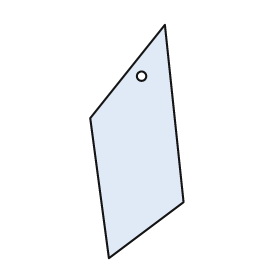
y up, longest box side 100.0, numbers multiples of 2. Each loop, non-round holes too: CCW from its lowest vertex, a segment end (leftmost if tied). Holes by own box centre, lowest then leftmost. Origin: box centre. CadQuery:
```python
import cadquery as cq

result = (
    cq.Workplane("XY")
    .moveTo(-12.0, -50.0)
    .lineTo(20.0, -26.0)
    .lineTo(12.0, 50.0)
    .lineTo(-20.0, 10.0)
    .close()
    .moveTo(2.0, 28.0)
    .circle(2.0)
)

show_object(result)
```